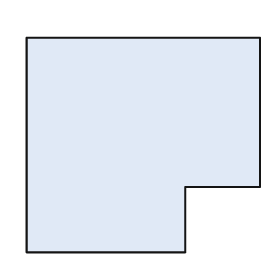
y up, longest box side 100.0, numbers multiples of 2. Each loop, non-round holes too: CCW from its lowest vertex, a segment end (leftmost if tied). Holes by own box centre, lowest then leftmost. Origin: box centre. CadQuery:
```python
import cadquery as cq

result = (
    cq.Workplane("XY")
    .moveTo(-50.0, -46.0)
    .lineTo(18.0, -46.0)
    .lineTo(18.0, -18.0)
    .lineTo(50.0, -18.0)
    .lineTo(50.0, 46.0)
    .lineTo(-50.0, 46.0)
    .close()
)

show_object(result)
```